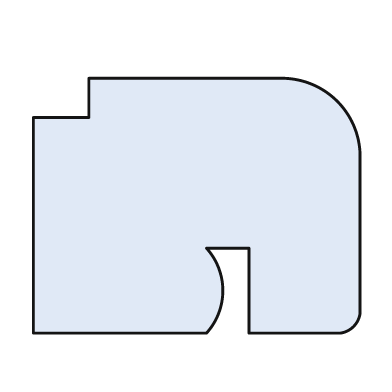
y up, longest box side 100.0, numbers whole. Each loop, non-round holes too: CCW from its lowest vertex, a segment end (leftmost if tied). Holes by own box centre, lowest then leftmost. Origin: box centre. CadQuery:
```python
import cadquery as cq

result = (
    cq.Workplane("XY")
    .moveTo(-50.0, -39.0)
    .lineTo(3.0, -39.0)
    .threePointArc((8.0, -26.0), (3.0, -13.0))
    .lineTo(16.0, -13.0)
    .lineTo(16.0, -39.0)
    .lineTo(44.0, -39.0)
    .threePointArc((48.0, -37.0), (50.0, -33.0))
    .lineTo(50.0, 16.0)
    .threePointArc((43.0, 32.0), (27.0, 39.0))
    .lineTo(-33.0, 39.0)
    .lineTo(-33.0, 27.0)
    .lineTo(-50.0, 27.0)
    .close()
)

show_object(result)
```